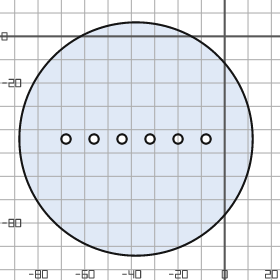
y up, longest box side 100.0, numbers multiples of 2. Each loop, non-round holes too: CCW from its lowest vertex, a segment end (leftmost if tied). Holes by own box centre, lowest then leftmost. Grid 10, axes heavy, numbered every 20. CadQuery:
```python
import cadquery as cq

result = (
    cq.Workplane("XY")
    .moveTo(-38.0, -44.0)
    .circle(50.0)
    .moveTo(-68.0, -44.0)
    .circle(2.0)
    .moveTo(-56.0, -44.0)
    .circle(2.0)
    .moveTo(-44.0, -44.0)
    .circle(2.0)
    .moveTo(-32.0, -44.0)
    .circle(2.0)
    .moveTo(-20.0, -44.0)
    .circle(2.0)
    .moveTo(-8.0, -44.0)
    .circle(2.0)
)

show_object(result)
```